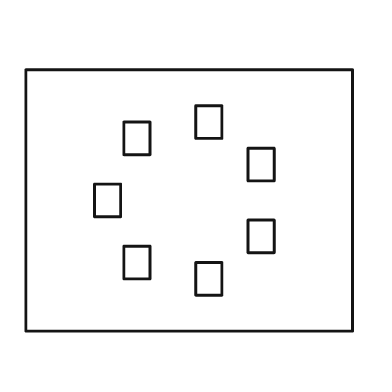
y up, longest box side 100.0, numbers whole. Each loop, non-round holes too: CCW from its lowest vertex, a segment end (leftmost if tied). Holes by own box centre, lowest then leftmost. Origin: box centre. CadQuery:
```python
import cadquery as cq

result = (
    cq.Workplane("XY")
    .moveTo(-50.0, -40.0)
    .lineTo(50.0, -40.0)
    .lineTo(50.0, 40.0)
    .lineTo(-50.0, 40.0)
    .close()
    .moveTo(2.0, -29.0)
    .lineTo(10.0, -29.0)
    .lineTo(10.0, -19.0)
    .lineTo(2.0, -19.0)
    .close()
    .moveTo(-20.0, -24.0)
    .lineTo(-12.0, -24.0)
    .lineTo(-12.0, -14.0)
    .lineTo(-20.0, -14.0)
    .close()
    .moveTo(18.0, -16.0)
    .lineTo(26.0, -16.0)
    .lineTo(26.0, -6.0)
    .lineTo(18.0, -6.0)
    .close()
    .moveTo(-29.0, -5.0)
    .lineTo(-21.0, -5.0)
    .lineTo(-21.0, 5.0)
    .lineTo(-29.0, 5.0)
    .close()
    .moveTo(18.0, 6.0)
    .lineTo(26.0, 6.0)
    .lineTo(26.0, 16.0)
    .lineTo(18.0, 16.0)
    .close()
    .moveTo(-20.0, 14.0)
    .lineTo(-12.0, 14.0)
    .lineTo(-12.0, 24.0)
    .lineTo(-20.0, 24.0)
    .close()
    .moveTo(2.0, 19.0)
    .lineTo(10.0, 19.0)
    .lineTo(10.0, 29.0)
    .lineTo(2.0, 29.0)
    .close()
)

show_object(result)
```